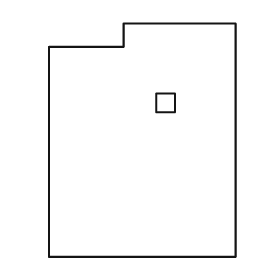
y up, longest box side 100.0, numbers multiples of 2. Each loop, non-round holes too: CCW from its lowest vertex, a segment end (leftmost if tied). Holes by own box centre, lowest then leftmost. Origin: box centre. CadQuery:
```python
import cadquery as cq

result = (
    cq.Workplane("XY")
    .moveTo(-40.0, -50.0)
    .lineTo(40.0, -50.0)
    .lineTo(40.0, 50.0)
    .lineTo(-8.0, 50.0)
    .lineTo(-8.0, 40.0)
    .lineTo(-40.0, 40.0)
    .close()
    .moveTo(6.0, 12.0)
    .lineTo(14.0, 12.0)
    .lineTo(14.0, 20.0)
    .lineTo(6.0, 20.0)
    .close()
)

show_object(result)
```